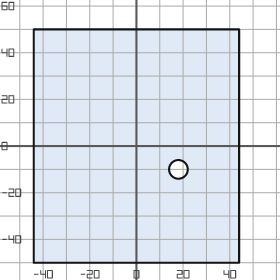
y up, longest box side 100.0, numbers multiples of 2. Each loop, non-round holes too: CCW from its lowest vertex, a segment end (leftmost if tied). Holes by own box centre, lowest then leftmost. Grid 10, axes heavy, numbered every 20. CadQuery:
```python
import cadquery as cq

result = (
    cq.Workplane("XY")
    .moveTo(-44.0, -50.0)
    .lineTo(44.0, -50.0)
    .lineTo(44.0, 50.0)
    .lineTo(-44.0, 50.0)
    .close()
    .moveTo(18.0, -10.0)
    .circle(4.0)
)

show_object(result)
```